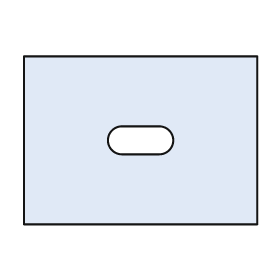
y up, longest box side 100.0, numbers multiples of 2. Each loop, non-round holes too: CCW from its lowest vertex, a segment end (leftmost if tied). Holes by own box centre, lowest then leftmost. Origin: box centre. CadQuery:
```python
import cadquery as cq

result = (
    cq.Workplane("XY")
    .moveTo(-50.0, -36.0)
    .lineTo(50.0, -36.0)
    .lineTo(50.0, 36.0)
    .lineTo(-50.0, 36.0)
    .close()
    .moveTo(-8.0, -6.0)
    .lineTo(8.0, -6.0)
    .threePointArc((14.0, 0.0), (8.0, 6.0))
    .lineTo(-8.0, 6.0)
    .threePointArc((-14.0, 0.0), (-8.0, -6.0))
    .close()
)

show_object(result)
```